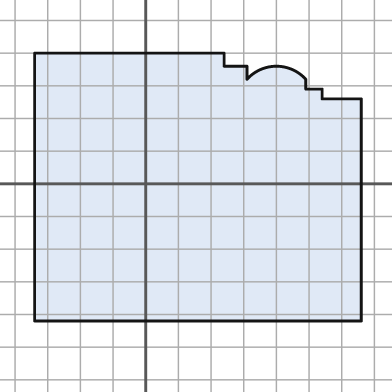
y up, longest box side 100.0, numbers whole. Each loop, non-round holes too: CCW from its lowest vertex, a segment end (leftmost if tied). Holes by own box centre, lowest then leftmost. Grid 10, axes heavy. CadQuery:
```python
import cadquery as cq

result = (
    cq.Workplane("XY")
    .moveTo(-34.0, -42.0)
    .lineTo(66.0, -42.0)
    .lineTo(66.0, 26.0)
    .lineTo(54.0, 26.0)
    .lineTo(54.0, 29.0)
    .lineTo(49.0, 29.0)
    .lineTo(49.0, 32.0)
    .threePointArc((40.0, 36.0), (31.0, 32.0))
    .lineTo(31.0, 36.0)
    .lineTo(24.0, 36.0)
    .lineTo(24.0, 40.0)
    .lineTo(-34.0, 40.0)
    .close()
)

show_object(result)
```